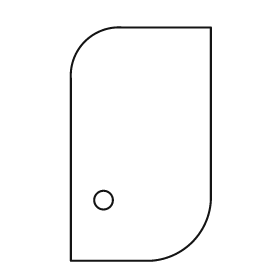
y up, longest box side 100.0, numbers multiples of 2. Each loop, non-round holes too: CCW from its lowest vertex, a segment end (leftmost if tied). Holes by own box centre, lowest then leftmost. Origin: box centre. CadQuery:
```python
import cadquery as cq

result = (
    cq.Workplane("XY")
    .moveTo(-30.0, -50.0)
    .lineTo(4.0, -50.0)
    .threePointArc((22.0, -42.0), (30.0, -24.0))
    .lineTo(30.0, 50.0)
    .lineTo(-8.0, 50.0)
    .threePointArc((-24.0, 44.0), (-30.0, 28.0))
    .close()
    .moveTo(-16.0, -24.0)
    .circle(4.0)
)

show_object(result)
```